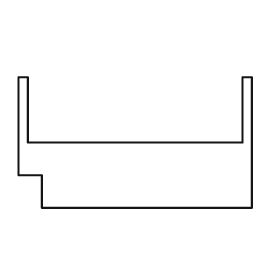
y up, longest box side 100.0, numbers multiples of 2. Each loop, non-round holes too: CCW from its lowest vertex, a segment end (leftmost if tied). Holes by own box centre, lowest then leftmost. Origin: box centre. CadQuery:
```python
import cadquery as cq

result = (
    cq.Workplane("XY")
    .moveTo(-40.0, -28.0)
    .lineTo(50.0, -28.0)
    .lineTo(50.0, 28.0)
    .lineTo(46.0, 28.0)
    .lineTo(46.0, 0.0)
    .lineTo(-46.0, 0.0)
    .lineTo(-46.0, 28.0)
    .lineTo(-50.0, 28.0)
    .lineTo(-50.0, -14.0)
    .lineTo(-40.0, -14.0)
    .close()
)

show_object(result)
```